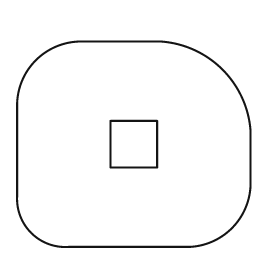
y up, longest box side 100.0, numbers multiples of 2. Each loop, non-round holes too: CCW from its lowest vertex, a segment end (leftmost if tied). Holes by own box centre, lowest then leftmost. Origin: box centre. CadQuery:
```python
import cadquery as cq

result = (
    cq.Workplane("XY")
    .moveTo(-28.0, -44.0)
    .lineTo(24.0, -44.0)
    .threePointArc((42.0, -36.0), (50.0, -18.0))
    .lineTo(50.0, 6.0)
    .threePointArc((38.0, 32.0), (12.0, 44.0))
    .lineTo(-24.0, 44.0)
    .threePointArc((-42.0, 36.0), (-50.0, 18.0))
    .lineTo(-50.0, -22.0)
    .threePointArc((-44.0, -38.0), (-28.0, -44.0))
    .close()
    .moveTo(-10.0, -10.0)
    .lineTo(10.0, -10.0)
    .lineTo(10.0, 10.0)
    .lineTo(-10.0, 10.0)
    .close()
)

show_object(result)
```